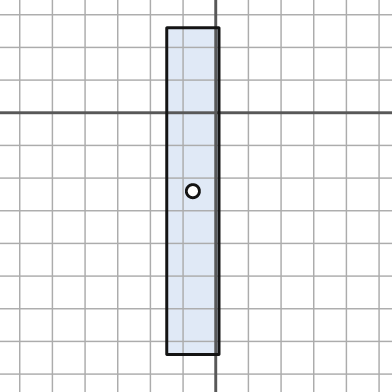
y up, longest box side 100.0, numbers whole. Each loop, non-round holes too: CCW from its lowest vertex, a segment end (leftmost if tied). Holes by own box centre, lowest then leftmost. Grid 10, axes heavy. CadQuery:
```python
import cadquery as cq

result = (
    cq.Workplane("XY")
    .moveTo(-15.0, -74.0)
    .lineTo(1.0, -74.0)
    .lineTo(1.0, 26.0)
    .lineTo(-15.0, 26.0)
    .close()
    .moveTo(-7.0, -24.0)
    .circle(2.0)
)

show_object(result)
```